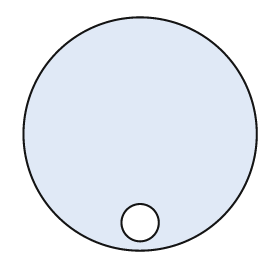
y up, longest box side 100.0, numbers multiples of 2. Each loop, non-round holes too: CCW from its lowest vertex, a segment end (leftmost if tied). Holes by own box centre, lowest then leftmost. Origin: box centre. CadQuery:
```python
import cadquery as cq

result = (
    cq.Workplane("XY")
    .moveTo(0.0, 0.0)
    .circle(50.0)
    .moveTo(0.0, -38.0)
    .circle(8.0)
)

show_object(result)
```